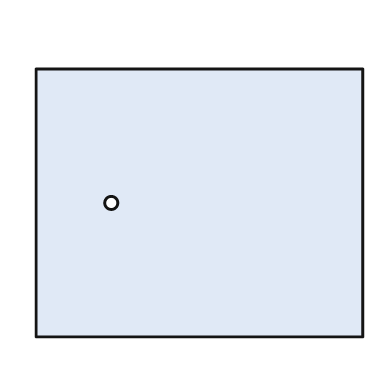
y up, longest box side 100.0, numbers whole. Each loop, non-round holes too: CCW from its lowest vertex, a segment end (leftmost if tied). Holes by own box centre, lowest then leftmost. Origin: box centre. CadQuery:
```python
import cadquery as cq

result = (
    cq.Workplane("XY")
    .moveTo(-50.0, -41.0)
    .lineTo(50.0, -41.0)
    .lineTo(50.0, 41.0)
    .lineTo(-50.0, 41.0)
    .close()
    .moveTo(-27.0, 0.0)
    .circle(2.0)
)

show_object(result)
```